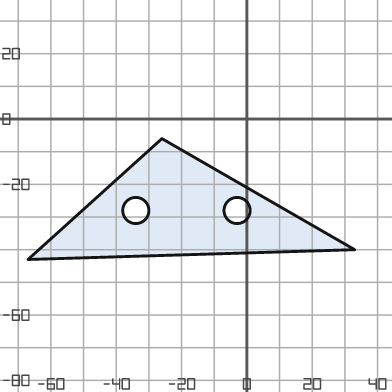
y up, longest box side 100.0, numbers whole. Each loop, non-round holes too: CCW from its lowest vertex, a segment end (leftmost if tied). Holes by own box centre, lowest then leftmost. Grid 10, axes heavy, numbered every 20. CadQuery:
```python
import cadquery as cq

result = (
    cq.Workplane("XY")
    .moveTo(-67.0, -43.0)
    .lineTo(33.0, -40.0)
    .lineTo(-26.0, -6.0)
    .close()
    .moveTo(-34.0, -28.0)
    .circle(4.0)
    .moveTo(-3.0, -28.0)
    .circle(4.0)
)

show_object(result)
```